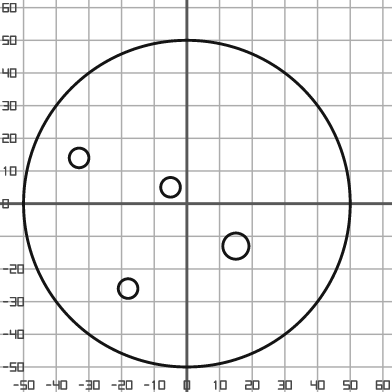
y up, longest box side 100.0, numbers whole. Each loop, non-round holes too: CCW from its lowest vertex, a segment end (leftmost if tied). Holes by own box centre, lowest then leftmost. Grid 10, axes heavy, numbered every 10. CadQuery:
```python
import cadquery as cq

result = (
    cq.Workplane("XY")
    .moveTo(0.0, 0.0)
    .circle(50.0)
    .moveTo(-18.0, -26.0)
    .circle(3.0)
    .moveTo(15.0, -13.0)
    .circle(4.0)
    .moveTo(-5.0, 5.0)
    .circle(3.0)
    .moveTo(-33.0, 14.0)
    .circle(3.0)
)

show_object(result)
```